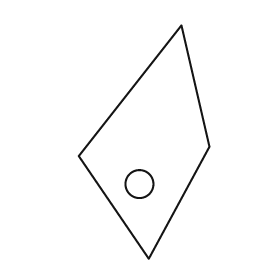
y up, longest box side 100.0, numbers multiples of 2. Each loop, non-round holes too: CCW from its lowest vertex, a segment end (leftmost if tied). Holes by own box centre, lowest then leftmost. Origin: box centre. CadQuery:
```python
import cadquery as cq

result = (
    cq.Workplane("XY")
    .moveTo(2.0, -50.0)
    .lineTo(28.0, -2.0)
    .lineTo(16.0, 50.0)
    .lineTo(-28.0, -6.0)
    .close()
    .moveTo(-2.0, -18.0)
    .circle(6.0)
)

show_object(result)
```